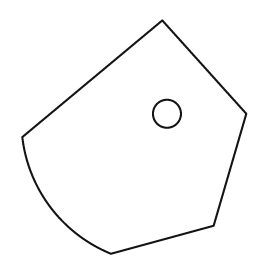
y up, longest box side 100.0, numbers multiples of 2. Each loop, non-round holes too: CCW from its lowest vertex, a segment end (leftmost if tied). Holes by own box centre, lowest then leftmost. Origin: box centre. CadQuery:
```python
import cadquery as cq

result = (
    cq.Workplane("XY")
    .moveTo(-10.0, -50.0)
    .lineTo(34.0, -38.0)
    .lineTo(48.0, 10.0)
    .lineTo(12.0, 50.0)
    .lineTo(-48.0, 0.0)
    .threePointArc((-36.0, -30.0), (-10.0, -50.0))
    .close()
    .moveTo(14.0, 10.0)
    .circle(6.0)
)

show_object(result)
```